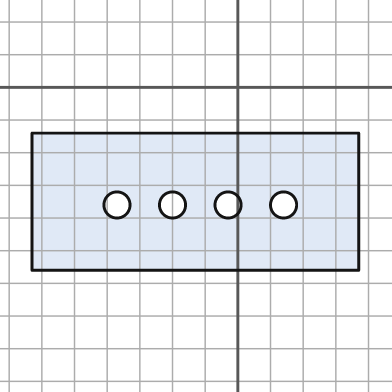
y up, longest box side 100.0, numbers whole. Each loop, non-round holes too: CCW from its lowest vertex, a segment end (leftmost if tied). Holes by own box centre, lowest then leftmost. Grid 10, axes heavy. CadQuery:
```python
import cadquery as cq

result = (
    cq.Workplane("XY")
    .moveTo(-63.0, -56.0)
    .lineTo(37.0, -56.0)
    .lineTo(37.0, -14.0)
    .lineTo(-63.0, -14.0)
    .close()
    .moveTo(-37.0, -36.0)
    .circle(4.0)
    .moveTo(-20.0, -36.0)
    .circle(4.0)
    .moveTo(-3.0, -36.0)
    .circle(4.0)
    .moveTo(14.0, -36.0)
    .circle(4.0)
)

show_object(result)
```